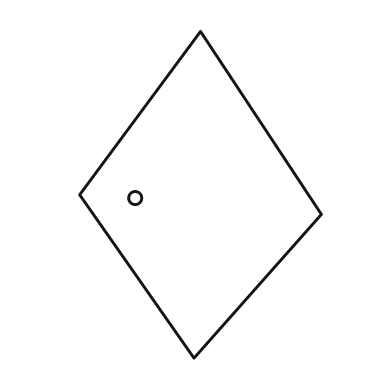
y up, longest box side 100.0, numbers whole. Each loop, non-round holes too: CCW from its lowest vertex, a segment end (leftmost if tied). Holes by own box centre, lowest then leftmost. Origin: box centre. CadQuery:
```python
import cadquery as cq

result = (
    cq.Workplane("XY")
    .moveTo(-2.0, -50.0)
    .lineTo(37.0, -6.0)
    .lineTo(0.0, 50.0)
    .lineTo(-37.0, 0.0)
    .close()
    .moveTo(-20.0, -1.0)
    .circle(2.0)
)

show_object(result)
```